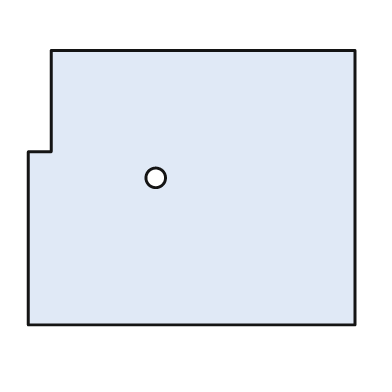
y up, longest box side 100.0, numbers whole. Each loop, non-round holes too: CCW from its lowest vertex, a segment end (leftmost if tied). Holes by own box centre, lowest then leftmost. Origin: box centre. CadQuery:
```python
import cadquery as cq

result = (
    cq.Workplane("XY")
    .moveTo(-50.0, -42.0)
    .lineTo(50.0, -42.0)
    .lineTo(50.0, 42.0)
    .lineTo(-43.0, 42.0)
    .lineTo(-43.0, 11.0)
    .lineTo(-50.0, 11.0)
    .close()
    .moveTo(-11.0, 3.0)
    .circle(3.0)
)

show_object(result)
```